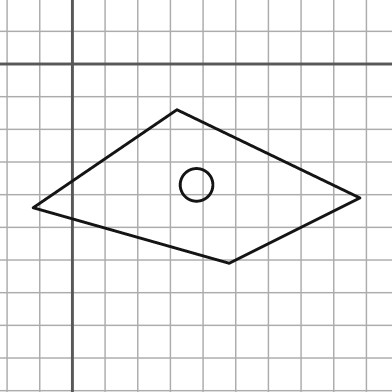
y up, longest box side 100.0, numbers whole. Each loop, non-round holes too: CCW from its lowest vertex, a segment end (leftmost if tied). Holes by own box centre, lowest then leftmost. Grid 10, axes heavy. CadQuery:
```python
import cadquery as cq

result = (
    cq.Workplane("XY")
    .moveTo(48.0, -61.0)
    .lineTo(88.0, -41.0)
    .lineTo(32.0, -14.0)
    .lineTo(-12.0, -44.0)
    .close()
    .moveTo(38.0, -37.0)
    .circle(5.0)
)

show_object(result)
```